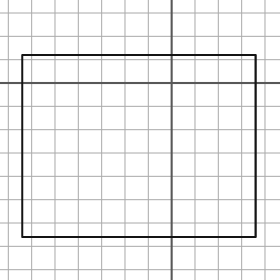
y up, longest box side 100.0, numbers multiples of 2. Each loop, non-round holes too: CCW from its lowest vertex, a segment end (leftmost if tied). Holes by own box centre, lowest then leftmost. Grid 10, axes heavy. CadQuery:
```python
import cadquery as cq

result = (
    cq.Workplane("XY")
    .moveTo(-64.0, -66.0)
    .lineTo(36.0, -66.0)
    .lineTo(36.0, 12.0)
    .lineTo(-64.0, 12.0)
    .close()
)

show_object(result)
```